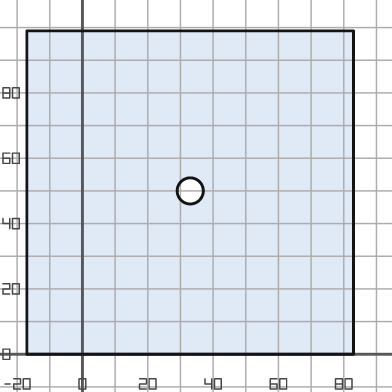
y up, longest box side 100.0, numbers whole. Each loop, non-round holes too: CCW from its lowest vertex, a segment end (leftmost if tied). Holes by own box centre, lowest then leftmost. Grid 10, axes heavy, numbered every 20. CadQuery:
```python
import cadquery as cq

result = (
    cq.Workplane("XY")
    .moveTo(-17.0, 0.0)
    .lineTo(83.0, 0.0)
    .lineTo(83.0, 99.0)
    .lineTo(-17.0, 99.0)
    .close()
    .moveTo(33.0, 50.0)
    .circle(4.0)
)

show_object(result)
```